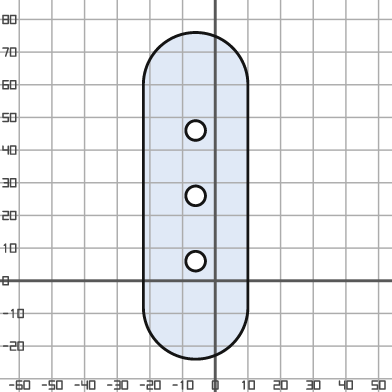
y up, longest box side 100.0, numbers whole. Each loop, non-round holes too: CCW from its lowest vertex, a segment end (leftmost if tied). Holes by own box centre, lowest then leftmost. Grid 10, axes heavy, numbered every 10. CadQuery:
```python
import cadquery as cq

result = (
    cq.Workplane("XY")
    .moveTo(-22.0, -8.0)
    .threePointArc((-6.0, -24.0), (10.0, -8.0))
    .lineTo(10.0, 60.0)
    .threePointArc((-6.0, 76.0), (-22.0, 60.0))
    .close()
    .moveTo(-6.0, 6.0)
    .circle(3.0)
    .moveTo(-6.0, 26.0)
    .circle(3.0)
    .moveTo(-6.0, 46.0)
    .circle(3.0)
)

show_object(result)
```